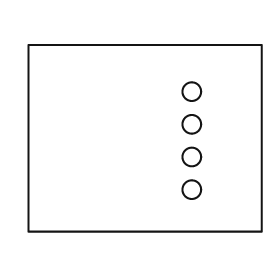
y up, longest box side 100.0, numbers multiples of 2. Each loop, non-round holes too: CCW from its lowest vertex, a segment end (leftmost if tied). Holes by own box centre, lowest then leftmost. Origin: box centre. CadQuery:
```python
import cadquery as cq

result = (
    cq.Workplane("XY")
    .moveTo(-50.0, -40.0)
    .lineTo(50.0, -40.0)
    .lineTo(50.0, 40.0)
    .lineTo(-50.0, 40.0)
    .close()
    .moveTo(20.0, -22.0)
    .circle(4.0)
    .moveTo(20.0, -8.0)
    .circle(4.0)
    .moveTo(20.0, 6.0)
    .circle(4.0)
    .moveTo(20.0, 20.0)
    .circle(4.0)
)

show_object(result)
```